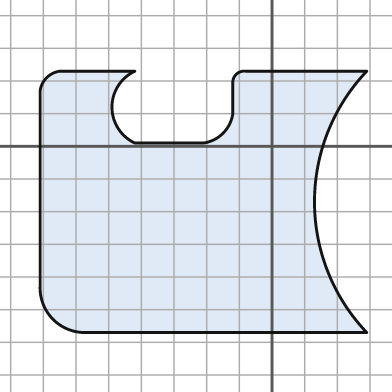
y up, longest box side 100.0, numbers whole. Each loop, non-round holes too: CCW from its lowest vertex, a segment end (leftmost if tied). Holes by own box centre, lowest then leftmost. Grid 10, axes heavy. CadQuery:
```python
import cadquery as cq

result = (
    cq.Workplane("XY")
    .moveTo(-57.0, -57.0)
    .lineTo(29.0, -57.0)
    .threePointArc((13.0, -17.0), (29.0, 23.0))
    .lineTo(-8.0, 23.0)
    .threePointArc((-11.0, 22.0), (-12.0, 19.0))
    .lineTo(-12.0, 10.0)
    .threePointArc((-15.0, 4.0), (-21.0, 1.0))
    .lineTo(-42.0, 1.0)
    .threePointArc((-49.0, 12.0), (-42.0, 23.0))
    .lineTo(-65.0, 23.0)
    .threePointArc((-69.0, 21.0), (-71.0, 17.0))
    .lineTo(-71.0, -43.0)
    .threePointArc((-67.0, -53.0), (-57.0, -57.0))
    .close()
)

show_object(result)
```